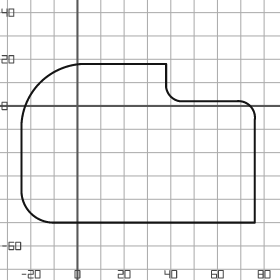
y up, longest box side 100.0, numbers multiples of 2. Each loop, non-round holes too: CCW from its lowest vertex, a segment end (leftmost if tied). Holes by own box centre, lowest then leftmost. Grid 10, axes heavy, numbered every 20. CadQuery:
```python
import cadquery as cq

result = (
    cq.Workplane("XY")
    .moveTo(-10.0, -50.0)
    .lineTo(76.0, -50.0)
    .lineTo(76.0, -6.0)
    .threePointArc((74.0, 0.0), (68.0, 2.0))
    .lineTo(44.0, 2.0)
    .threePointArc((40.0, 4.0), (38.0, 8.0))
    .lineTo(38.0, 18.0)
    .lineTo(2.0, 18.0)
    .threePointArc((-16.0, 10.0), (-24.0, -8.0))
    .lineTo(-24.0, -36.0)
    .threePointArc((-20.0, -46.0), (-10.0, -50.0))
    .close()
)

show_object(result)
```